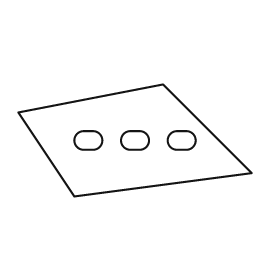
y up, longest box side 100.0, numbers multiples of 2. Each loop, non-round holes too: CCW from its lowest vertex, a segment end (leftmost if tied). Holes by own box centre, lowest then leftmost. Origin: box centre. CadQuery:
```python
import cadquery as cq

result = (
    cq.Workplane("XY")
    .moveTo(-26.0, -24.0)
    .lineTo(50.0, -14.0)
    .lineTo(12.0, 24.0)
    .lineTo(-50.0, 12.0)
    .close()
    .moveTo(-22.0, -4.0)
    .lineTo(-18.0, -4.0)
    .threePointArc((-14.0, 0.0), (-18.0, 4.0))
    .lineTo(-22.0, 4.0)
    .threePointArc((-26.0, 0.0), (-22.0, -4.0))
    .close()
    .moveTo(-2.0, -4.0)
    .lineTo(2.0, -4.0)
    .threePointArc((6.0, 0.0), (2.0, 4.0))
    .lineTo(-2.0, 4.0)
    .threePointArc((-6.0, 0.0), (-2.0, -4.0))
    .close()
    .moveTo(18.0, -4.0)
    .lineTo(22.0, -4.0)
    .threePointArc((26.0, 0.0), (22.0, 4.0))
    .lineTo(18.0, 4.0)
    .threePointArc((14.0, 0.0), (18.0, -4.0))
    .close()
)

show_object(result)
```